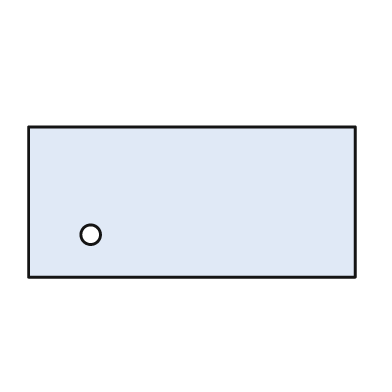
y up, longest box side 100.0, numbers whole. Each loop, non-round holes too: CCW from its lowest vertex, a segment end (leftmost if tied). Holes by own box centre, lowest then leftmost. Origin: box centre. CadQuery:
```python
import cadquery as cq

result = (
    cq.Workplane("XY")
    .moveTo(-50.0, -23.0)
    .lineTo(50.0, -23.0)
    .lineTo(50.0, 23.0)
    .lineTo(-50.0, 23.0)
    .close()
    .moveTo(-31.0, -10.0)
    .circle(3.0)
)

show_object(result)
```